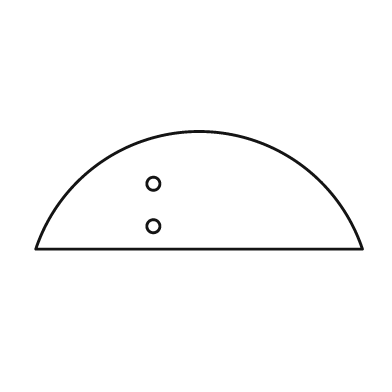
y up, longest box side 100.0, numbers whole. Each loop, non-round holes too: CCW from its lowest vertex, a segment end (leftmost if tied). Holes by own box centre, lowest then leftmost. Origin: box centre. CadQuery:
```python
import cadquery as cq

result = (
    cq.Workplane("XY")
    .moveTo(-50.0, -18.0)
    .lineTo(50.0, -18.0)
    .threePointArc((0.0, 18.0), (-50.0, -18.0))
    .close()
    .moveTo(-14.0, -11.0)
    .circle(2.0)
    .moveTo(-14.0, 2.0)
    .circle(2.0)
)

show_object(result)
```